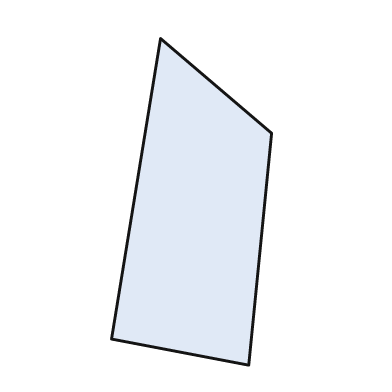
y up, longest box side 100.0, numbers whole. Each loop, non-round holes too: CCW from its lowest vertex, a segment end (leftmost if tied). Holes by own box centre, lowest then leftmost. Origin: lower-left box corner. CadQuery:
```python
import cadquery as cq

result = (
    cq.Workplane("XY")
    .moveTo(42.0, 0.0)
    .lineTo(49.0, 71.0)
    .lineTo(15.0, 100.0)
    .lineTo(0.0, 8.0)
    .close()
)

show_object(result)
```